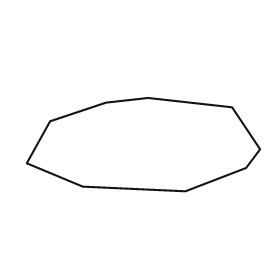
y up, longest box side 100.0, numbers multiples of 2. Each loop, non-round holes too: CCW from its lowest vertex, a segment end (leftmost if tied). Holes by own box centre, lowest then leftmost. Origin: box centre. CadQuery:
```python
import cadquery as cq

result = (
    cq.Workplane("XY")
    .moveTo(18.0, -20.0)
    .lineTo(44.0, -10.0)
    .lineTo(50.0, -2.0)
    .lineTo(38.0, 16.0)
    .lineTo(2.0, 20.0)
    .lineTo(-16.0, 18.0)
    .lineTo(-40.0, 10.0)
    .lineTo(-50.0, -8.0)
    .lineTo(-26.0, -18.0)
    .close()
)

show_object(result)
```